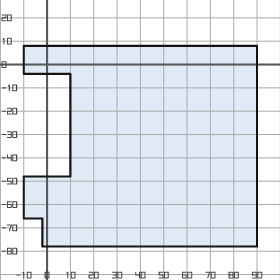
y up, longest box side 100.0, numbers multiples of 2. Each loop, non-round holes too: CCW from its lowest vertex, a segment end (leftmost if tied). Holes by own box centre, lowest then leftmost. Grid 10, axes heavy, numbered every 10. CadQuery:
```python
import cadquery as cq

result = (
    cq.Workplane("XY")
    .moveTo(-2.0, -78.0)
    .lineTo(90.0, -78.0)
    .lineTo(90.0, 8.0)
    .lineTo(-10.0, 8.0)
    .lineTo(-10.0, -4.0)
    .lineTo(10.0, -4.0)
    .lineTo(10.0, -48.0)
    .lineTo(-10.0, -48.0)
    .lineTo(-10.0, -66.0)
    .lineTo(-2.0, -66.0)
    .close()
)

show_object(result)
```